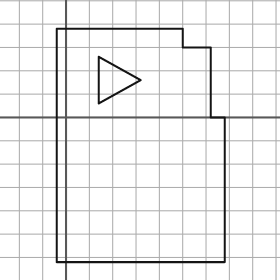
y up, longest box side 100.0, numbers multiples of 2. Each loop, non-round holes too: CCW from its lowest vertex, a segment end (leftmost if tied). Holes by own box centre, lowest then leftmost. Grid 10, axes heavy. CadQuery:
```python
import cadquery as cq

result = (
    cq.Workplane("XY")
    .moveTo(-4.0, -62.0)
    .lineTo(68.0, -62.0)
    .lineTo(68.0, 0.0)
    .lineTo(62.0, 0.0)
    .lineTo(62.0, 30.0)
    .lineTo(50.0, 30.0)
    .lineTo(50.0, 38.0)
    .lineTo(-4.0, 38.0)
    .close()
    .moveTo(14.0, 6.0)
    .lineTo(32.0, 16.0)
    .lineTo(14.0, 26.0)
    .close()
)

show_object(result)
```